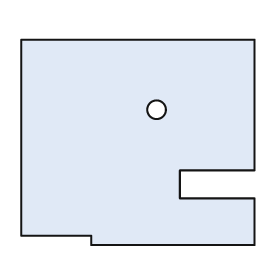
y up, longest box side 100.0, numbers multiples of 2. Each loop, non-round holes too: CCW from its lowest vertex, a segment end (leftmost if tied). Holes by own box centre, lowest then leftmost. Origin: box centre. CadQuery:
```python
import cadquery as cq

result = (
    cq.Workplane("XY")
    .moveTo(-20.0, -44.0)
    .lineTo(50.0, -44.0)
    .lineTo(50.0, -24.0)
    .lineTo(18.0, -24.0)
    .lineTo(18.0, -12.0)
    .lineTo(50.0, -12.0)
    .lineTo(50.0, 44.0)
    .lineTo(-50.0, 44.0)
    .lineTo(-50.0, -40.0)
    .lineTo(-20.0, -40.0)
    .close()
    .moveTo(8.0, 14.0)
    .circle(4.0)
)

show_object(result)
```